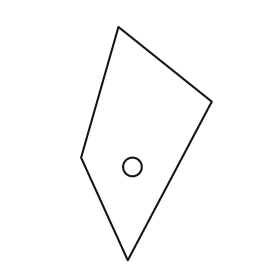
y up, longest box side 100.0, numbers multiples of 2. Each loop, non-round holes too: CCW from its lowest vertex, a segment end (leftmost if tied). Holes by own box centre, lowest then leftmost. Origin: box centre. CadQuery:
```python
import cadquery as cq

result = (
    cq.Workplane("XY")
    .moveTo(-8.0, -50.0)
    .lineTo(28.0, 18.0)
    .lineTo(-12.0, 50.0)
    .lineTo(-28.0, -6.0)
    .close()
    .moveTo(-6.0, -10.0)
    .circle(4.0)
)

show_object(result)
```